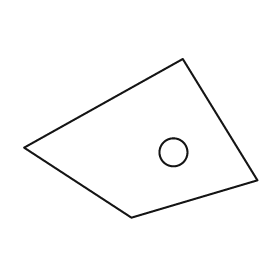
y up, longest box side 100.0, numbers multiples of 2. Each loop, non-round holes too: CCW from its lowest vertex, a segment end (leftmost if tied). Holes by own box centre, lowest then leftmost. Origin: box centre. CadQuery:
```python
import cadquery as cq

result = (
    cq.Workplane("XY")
    .moveTo(-4.0, -34.0)
    .lineTo(50.0, -18.0)
    .lineTo(18.0, 34.0)
    .lineTo(-50.0, -4.0)
    .close()
    .moveTo(14.0, -6.0)
    .circle(6.0)
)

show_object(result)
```